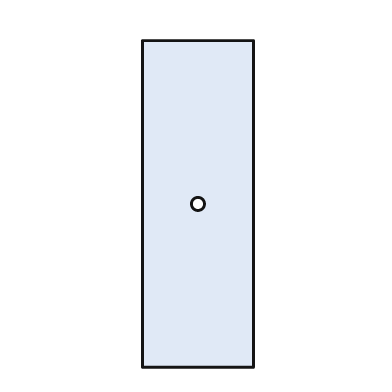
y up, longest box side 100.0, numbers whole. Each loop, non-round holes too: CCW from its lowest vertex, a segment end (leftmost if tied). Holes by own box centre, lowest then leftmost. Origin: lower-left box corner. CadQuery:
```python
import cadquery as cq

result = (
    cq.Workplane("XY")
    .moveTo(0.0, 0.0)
    .lineTo(34.0, 0.0)
    .lineTo(34.0, 100.0)
    .lineTo(0.0, 100.0)
    .close()
    .moveTo(17.0, 50.0)
    .circle(2.0)
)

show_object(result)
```